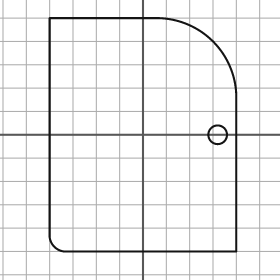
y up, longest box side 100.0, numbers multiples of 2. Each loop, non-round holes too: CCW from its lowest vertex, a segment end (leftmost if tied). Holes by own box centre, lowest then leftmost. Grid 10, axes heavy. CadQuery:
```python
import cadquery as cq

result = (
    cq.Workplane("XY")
    .moveTo(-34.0, -50.0)
    .lineTo(40.0, -50.0)
    .lineTo(40.0, 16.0)
    .threePointArc((30.0, 40.0), (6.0, 50.0))
    .lineTo(-40.0, 50.0)
    .lineTo(-40.0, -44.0)
    .threePointArc((-38.0, -48.0), (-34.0, -50.0))
    .close()
    .moveTo(32.0, 0.0)
    .circle(4.0)
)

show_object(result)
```